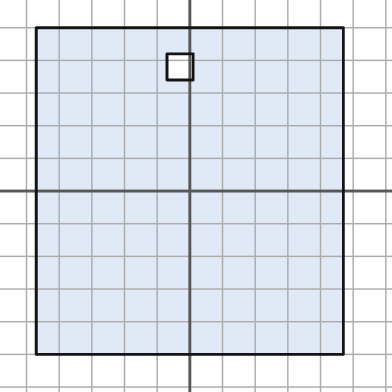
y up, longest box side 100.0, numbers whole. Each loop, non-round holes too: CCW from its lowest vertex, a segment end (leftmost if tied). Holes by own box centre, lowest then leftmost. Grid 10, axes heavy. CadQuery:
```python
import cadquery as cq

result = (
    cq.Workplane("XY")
    .moveTo(-47.0, -50.0)
    .lineTo(47.0, -50.0)
    .lineTo(47.0, 50.0)
    .lineTo(-47.0, 50.0)
    .close()
    .moveTo(-7.0, 34.0)
    .lineTo(1.0, 34.0)
    .lineTo(1.0, 42.0)
    .lineTo(-7.0, 42.0)
    .close()
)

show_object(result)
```